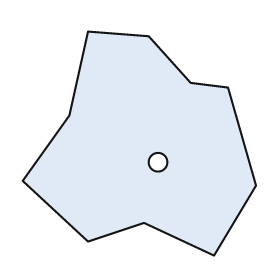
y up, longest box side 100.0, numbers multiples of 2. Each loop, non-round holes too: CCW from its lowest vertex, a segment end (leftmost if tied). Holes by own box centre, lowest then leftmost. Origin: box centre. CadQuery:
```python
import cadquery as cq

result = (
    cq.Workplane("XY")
    .moveTo(32.0, -48.0)
    .lineTo(50.0, -18.0)
    .lineTo(38.0, 24.0)
    .lineTo(22.0, 26.0)
    .lineTo(4.0, 46.0)
    .lineTo(-22.0, 48.0)
    .lineTo(-30.0, 12.0)
    .lineTo(-50.0, -16.0)
    .lineTo(-22.0, -42.0)
    .lineTo(2.0, -34.0)
    .close()
    .moveTo(8.0, -8.0)
    .circle(4.0)
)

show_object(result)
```